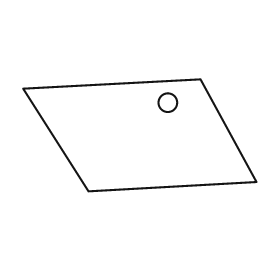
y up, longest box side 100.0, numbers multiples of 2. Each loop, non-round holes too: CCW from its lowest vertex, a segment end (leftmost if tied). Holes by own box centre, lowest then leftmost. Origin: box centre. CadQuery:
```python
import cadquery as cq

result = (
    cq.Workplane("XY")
    .moveTo(-22.0, -24.0)
    .lineTo(50.0, -20.0)
    .lineTo(26.0, 24.0)
    .lineTo(-50.0, 20.0)
    .close()
    .moveTo(12.0, 14.0)
    .circle(4.0)
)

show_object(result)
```